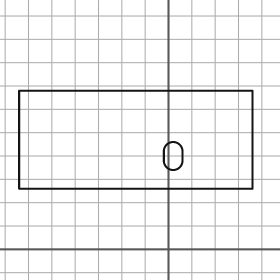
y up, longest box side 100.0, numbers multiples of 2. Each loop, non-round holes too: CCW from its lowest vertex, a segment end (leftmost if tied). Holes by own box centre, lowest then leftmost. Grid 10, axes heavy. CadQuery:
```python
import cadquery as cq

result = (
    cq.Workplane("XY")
    .moveTo(-64.0, 26.0)
    .lineTo(36.0, 26.0)
    .lineTo(36.0, 68.0)
    .lineTo(-64.0, 68.0)
    .close()
    .moveTo(-2.0, 38.0)
    .threePointArc((2.0, 34.0), (6.0, 38.0))
    .lineTo(6.0, 42.0)
    .threePointArc((2.0, 46.0), (-2.0, 42.0))
    .close()
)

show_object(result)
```